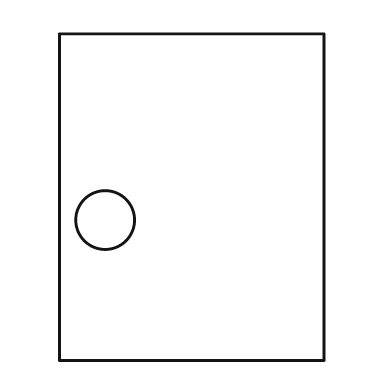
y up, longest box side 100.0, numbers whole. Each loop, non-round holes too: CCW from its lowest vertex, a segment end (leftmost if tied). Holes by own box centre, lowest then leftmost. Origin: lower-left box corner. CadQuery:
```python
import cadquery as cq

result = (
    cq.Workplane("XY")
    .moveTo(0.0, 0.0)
    .lineTo(81.0, 0.0)
    .lineTo(81.0, 100.0)
    .lineTo(0.0, 100.0)
    .close()
    .moveTo(14.0, 43.0)
    .circle(9.0)
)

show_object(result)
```